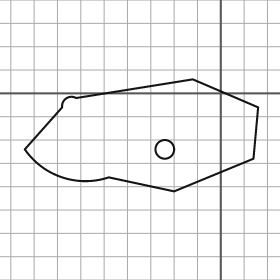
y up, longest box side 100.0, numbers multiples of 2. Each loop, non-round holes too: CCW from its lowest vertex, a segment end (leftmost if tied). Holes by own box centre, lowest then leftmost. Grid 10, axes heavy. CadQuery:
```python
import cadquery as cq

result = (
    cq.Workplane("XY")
    .moveTo(-20.0, -42.0)
    .lineTo(14.0, -28.0)
    .lineTo(16.0, -6.0)
    .lineTo(-12.0, 6.0)
    .lineTo(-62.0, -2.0)
    .threePointArc((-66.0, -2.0), (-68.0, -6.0))
    .lineTo(-84.0, -24.0)
    .threePointArc((-68.0, -36.0), (-48.0, -36.0))
    .close()
    .moveTo(-24.0, -24.0)
    .circle(4.0)
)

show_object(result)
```